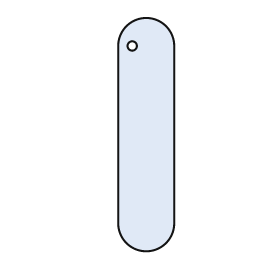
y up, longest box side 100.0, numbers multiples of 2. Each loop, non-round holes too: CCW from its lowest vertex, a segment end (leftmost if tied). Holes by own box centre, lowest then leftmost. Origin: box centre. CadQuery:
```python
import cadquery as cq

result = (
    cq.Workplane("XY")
    .moveTo(-12.0, -38.0)
    .threePointArc((0.0, -50.0), (12.0, -38.0))
    .lineTo(12.0, 38.0)
    .threePointArc((0.0, 50.0), (-12.0, 38.0))
    .close()
    .moveTo(-6.0, 38.0)
    .circle(2.0)
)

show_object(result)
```